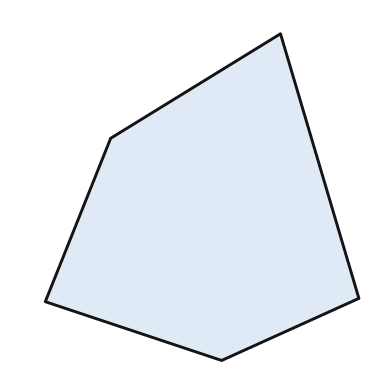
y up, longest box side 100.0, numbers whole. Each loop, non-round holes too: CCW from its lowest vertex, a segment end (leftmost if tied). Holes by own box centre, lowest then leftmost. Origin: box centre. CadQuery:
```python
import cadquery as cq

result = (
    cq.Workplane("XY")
    .moveTo(6.0, -50.0)
    .lineTo(48.0, -31.0)
    .lineTo(24.0, 50.0)
    .lineTo(-28.0, 18.0)
    .lineTo(-48.0, -32.0)
    .close()
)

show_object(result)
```